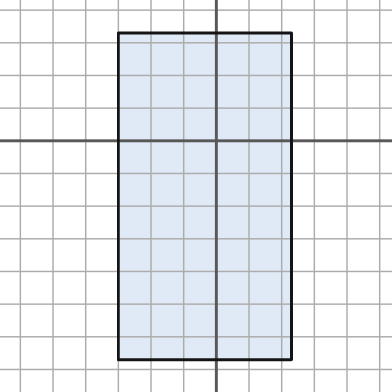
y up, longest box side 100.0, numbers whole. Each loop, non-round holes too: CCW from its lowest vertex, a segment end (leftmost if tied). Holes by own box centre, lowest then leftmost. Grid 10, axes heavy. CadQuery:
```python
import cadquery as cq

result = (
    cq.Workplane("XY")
    .moveTo(-30.0, -67.0)
    .lineTo(23.0, -67.0)
    .lineTo(23.0, 33.0)
    .lineTo(-30.0, 33.0)
    .close()
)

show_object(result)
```